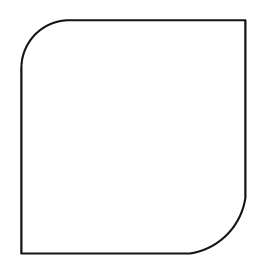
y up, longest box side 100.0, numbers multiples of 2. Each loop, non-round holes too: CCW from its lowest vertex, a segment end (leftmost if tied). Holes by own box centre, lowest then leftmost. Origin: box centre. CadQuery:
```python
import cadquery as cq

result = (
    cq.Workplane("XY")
    .moveTo(-48.0, -50.0)
    .lineTo(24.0, -50.0)
    .threePointArc((40.0, -42.0), (48.0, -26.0))
    .lineTo(48.0, 50.0)
    .lineTo(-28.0, 50.0)
    .threePointArc((-42.0, 44.0), (-48.0, 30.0))
    .close()
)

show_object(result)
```